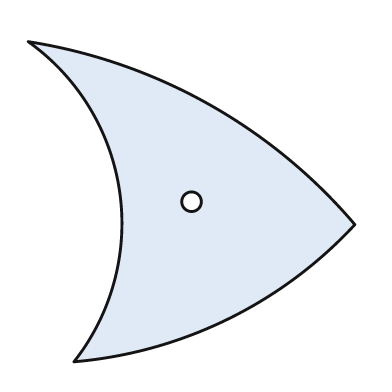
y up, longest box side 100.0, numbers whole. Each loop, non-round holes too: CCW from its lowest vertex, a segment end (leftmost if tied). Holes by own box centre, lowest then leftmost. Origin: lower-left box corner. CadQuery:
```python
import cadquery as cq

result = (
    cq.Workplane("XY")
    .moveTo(14.0, 0.0)
    .threePointArc((61.0, 13.0), (100.0, 42.0))
    .threePointArc((55.0, 79.0), (0.0, 98.0))
    .threePointArc((28.0, 52.0), (14.0, 0.0))
    .close()
    .moveTo(50.0, 49.0)
    .circle(3.0)
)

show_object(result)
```